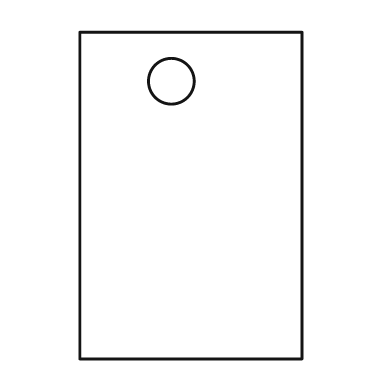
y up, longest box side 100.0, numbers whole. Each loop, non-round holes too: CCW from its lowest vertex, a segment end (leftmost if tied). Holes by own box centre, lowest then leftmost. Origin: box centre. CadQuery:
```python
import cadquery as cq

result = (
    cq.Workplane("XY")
    .moveTo(-34.0, -50.0)
    .lineTo(34.0, -50.0)
    .lineTo(34.0, 50.0)
    .lineTo(-34.0, 50.0)
    .close()
    .moveTo(-6.0, 35.0)
    .circle(7.0)
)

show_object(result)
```